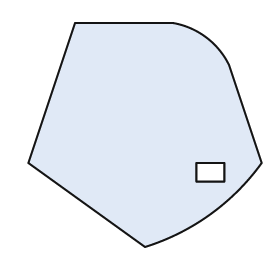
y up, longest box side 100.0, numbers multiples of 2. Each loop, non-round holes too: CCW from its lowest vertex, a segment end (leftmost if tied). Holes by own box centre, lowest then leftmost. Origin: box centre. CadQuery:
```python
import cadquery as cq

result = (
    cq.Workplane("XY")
    .moveTo(0.0, -48.0)
    .threePointArc((28.0, -34.0), (50.0, -12.0))
    .lineTo(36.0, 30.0)
    .threePointArc((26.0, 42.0), (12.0, 48.0))
    .lineTo(-30.0, 48.0)
    .lineTo(-50.0, -12.0)
    .close()
    .moveTo(22.0, -20.0)
    .lineTo(34.0, -20.0)
    .lineTo(34.0, -12.0)
    .lineTo(22.0, -12.0)
    .close()
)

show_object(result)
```